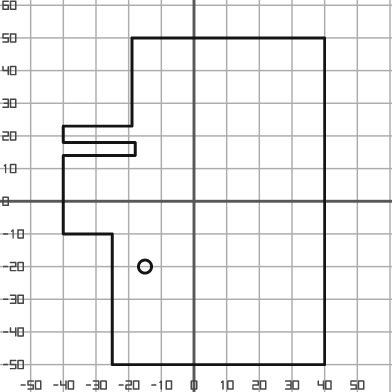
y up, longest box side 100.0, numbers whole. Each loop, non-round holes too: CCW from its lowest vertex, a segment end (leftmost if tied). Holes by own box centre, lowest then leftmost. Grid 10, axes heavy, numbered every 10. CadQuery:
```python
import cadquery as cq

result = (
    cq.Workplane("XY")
    .moveTo(-25.0, -50.0)
    .lineTo(40.0, -50.0)
    .lineTo(40.0, 50.0)
    .lineTo(-19.0, 50.0)
    .lineTo(-19.0, 23.0)
    .lineTo(-40.0, 23.0)
    .lineTo(-40.0, 18.0)
    .lineTo(-18.0, 18.0)
    .lineTo(-18.0, 14.0)
    .lineTo(-40.0, 14.0)
    .lineTo(-40.0, -10.0)
    .lineTo(-25.0, -10.0)
    .close()
    .moveTo(-15.0, -20.0)
    .circle(2.0)
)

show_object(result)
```